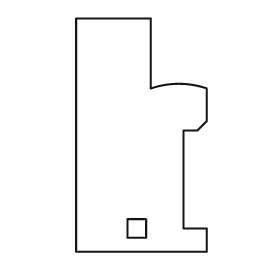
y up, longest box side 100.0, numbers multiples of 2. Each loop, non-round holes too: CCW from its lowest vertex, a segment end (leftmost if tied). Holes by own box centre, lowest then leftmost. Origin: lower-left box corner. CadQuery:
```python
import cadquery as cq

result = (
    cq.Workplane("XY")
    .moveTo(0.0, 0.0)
    .lineTo(56.0, 0.0)
    .lineTo(56.0, 10.0)
    .lineTo(46.0, 10.0)
    .lineTo(46.0, 52.0)
    .lineTo(52.0, 52.0)
    .lineTo(56.0, 56.0)
    .lineTo(56.0, 70.0)
    .threePointArc((44.0, 72.0), (32.0, 70.0))
    .lineTo(32.0, 100.0)
    .lineTo(0.0, 100.0)
    .close()
    .moveTo(22.0, 6.0)
    .lineTo(30.0, 6.0)
    .lineTo(30.0, 14.0)
    .lineTo(22.0, 14.0)
    .close()
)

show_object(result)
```